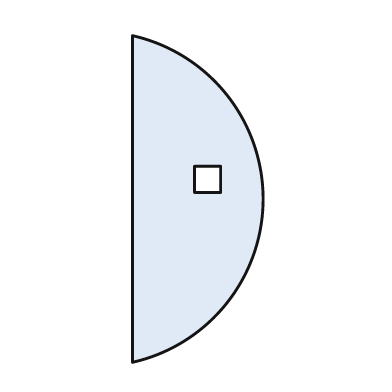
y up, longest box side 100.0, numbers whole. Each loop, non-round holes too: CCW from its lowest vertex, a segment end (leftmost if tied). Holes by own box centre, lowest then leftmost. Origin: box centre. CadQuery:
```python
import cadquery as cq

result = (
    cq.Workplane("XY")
    .moveTo(-20.0, -50.0)
    .threePointArc((20.0, 0.0), (-20.0, 50.0))
    .close()
    .moveTo(-1.0, 2.0)
    .lineTo(7.0, 2.0)
    .lineTo(7.0, 10.0)
    .lineTo(-1.0, 10.0)
    .close()
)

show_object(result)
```